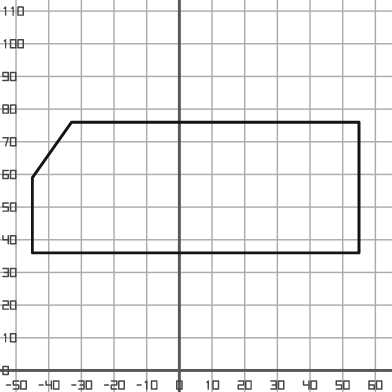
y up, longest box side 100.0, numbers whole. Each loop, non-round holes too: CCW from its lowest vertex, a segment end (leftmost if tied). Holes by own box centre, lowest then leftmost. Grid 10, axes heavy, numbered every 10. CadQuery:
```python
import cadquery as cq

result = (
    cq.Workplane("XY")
    .moveTo(-45.0, 36.0)
    .lineTo(55.0, 36.0)
    .lineTo(55.0, 76.0)
    .lineTo(-33.0, 76.0)
    .lineTo(-45.0, 59.0)
    .close()
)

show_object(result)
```